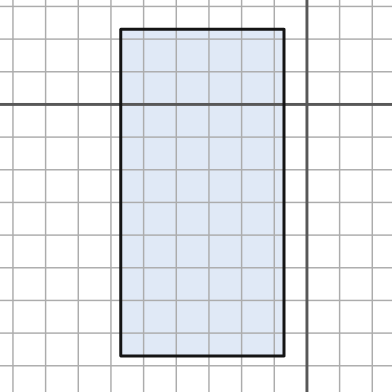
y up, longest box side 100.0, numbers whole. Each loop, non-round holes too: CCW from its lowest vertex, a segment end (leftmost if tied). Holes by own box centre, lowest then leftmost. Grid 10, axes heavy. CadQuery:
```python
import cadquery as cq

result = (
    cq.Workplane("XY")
    .moveTo(-57.0, -77.0)
    .lineTo(-7.0, -77.0)
    .lineTo(-7.0, 23.0)
    .lineTo(-57.0, 23.0)
    .close()
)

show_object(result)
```